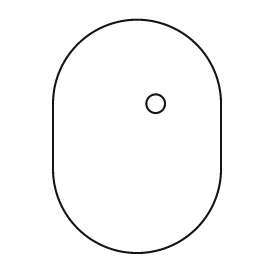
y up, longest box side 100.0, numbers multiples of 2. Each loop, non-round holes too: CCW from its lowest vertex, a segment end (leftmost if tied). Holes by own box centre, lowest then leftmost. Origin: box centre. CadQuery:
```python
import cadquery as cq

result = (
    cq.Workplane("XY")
    .moveTo(-36.0, -14.0)
    .threePointArc((0.0, -50.0), (36.0, -14.0))
    .lineTo(36.0, 14.0)
    .threePointArc((0.0, 50.0), (-36.0, 14.0))
    .close()
    .moveTo(8.0, 14.0)
    .circle(4.0)
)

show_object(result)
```